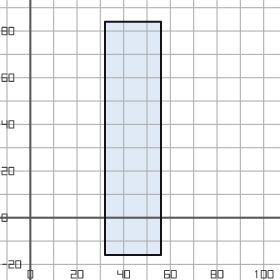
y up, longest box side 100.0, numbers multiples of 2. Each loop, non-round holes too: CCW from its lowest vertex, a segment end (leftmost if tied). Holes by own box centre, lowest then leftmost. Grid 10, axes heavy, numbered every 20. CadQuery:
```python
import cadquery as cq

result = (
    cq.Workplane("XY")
    .moveTo(32.0, -16.0)
    .lineTo(56.0, -16.0)
    .lineTo(56.0, 84.0)
    .lineTo(32.0, 84.0)
    .close()
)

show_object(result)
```